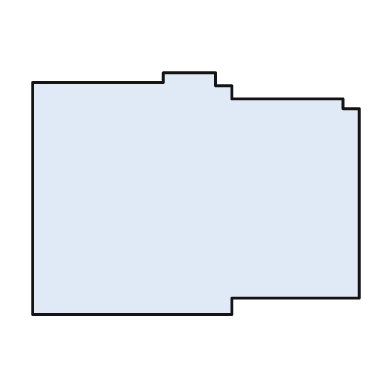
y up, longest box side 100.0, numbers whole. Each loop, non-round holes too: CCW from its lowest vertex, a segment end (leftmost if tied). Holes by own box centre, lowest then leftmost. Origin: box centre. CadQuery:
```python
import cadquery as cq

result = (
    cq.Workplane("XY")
    .moveTo(-50.0, -37.0)
    .lineTo(11.0, -37.0)
    .lineTo(11.0, -32.0)
    .lineTo(50.0, -32.0)
    .lineTo(50.0, 26.0)
    .lineTo(45.0, 26.0)
    .lineTo(45.0, 29.0)
    .lineTo(11.0, 29.0)
    .lineTo(11.0, 33.0)
    .lineTo(6.0, 33.0)
    .lineTo(6.0, 37.0)
    .lineTo(-10.0, 37.0)
    .lineTo(-10.0, 34.0)
    .lineTo(-50.0, 34.0)
    .close()
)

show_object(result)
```